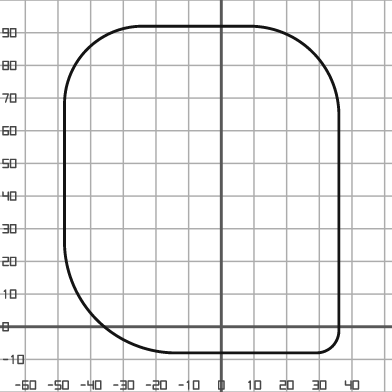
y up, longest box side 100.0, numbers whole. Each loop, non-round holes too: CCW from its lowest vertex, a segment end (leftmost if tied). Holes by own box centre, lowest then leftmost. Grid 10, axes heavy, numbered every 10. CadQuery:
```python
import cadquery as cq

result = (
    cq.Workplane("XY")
    .moveTo(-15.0, -8.0)
    .lineTo(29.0, -8.0)
    .threePointArc((34.0, -6.0), (36.0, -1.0))
    .lineTo(36.0, 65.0)
    .threePointArc((28.0, 84.0), (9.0, 92.0))
    .lineTo(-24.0, 92.0)
    .threePointArc((-41.0, 85.0), (-48.0, 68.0))
    .lineTo(-48.0, 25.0)
    .threePointArc((-38.0, 2.0), (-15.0, -8.0))
    .close()
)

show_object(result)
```